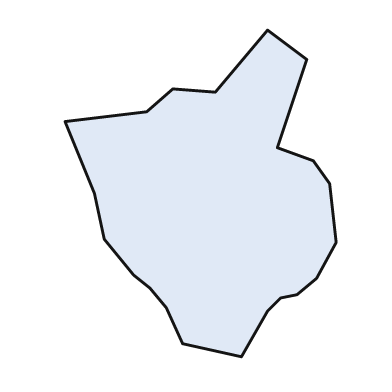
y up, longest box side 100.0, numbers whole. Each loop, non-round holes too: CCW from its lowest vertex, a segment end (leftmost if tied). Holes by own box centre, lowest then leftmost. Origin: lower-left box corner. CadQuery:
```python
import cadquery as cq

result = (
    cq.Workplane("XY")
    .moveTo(54.0, 0.0)
    .lineTo(62.0, 14.0)
    .lineTo(66.0, 18.0)
    .lineTo(71.0, 19.0)
    .lineTo(77.0, 24.0)
    .lineTo(83.0, 35.0)
    .lineTo(81.0, 53.0)
    .lineTo(76.0, 60.0)
    .lineTo(65.0, 64.0)
    .lineTo(74.0, 91.0)
    .lineTo(62.0, 100.0)
    .lineTo(46.0, 81.0)
    .lineTo(33.0, 82.0)
    .lineTo(25.0, 75.0)
    .lineTo(0.0, 72.0)
    .lineTo(9.0, 50.0)
    .lineTo(12.0, 36.0)
    .lineTo(21.0, 25.0)
    .lineTo(26.0, 21.0)
    .lineTo(31.0, 15.0)
    .lineTo(36.0, 4.0)
    .close()
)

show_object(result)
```